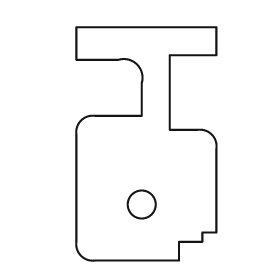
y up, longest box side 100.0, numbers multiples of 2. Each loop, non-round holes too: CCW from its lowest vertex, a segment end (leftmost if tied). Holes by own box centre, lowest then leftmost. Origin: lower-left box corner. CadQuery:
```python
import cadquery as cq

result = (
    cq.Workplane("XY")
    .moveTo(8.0, 0.0)
    .lineTo(44.0, 0.0)
    .lineTo(44.0, 8.0)
    .lineTo(54.0, 8.0)
    .lineTo(54.0, 12.0)
    .lineTo(60.0, 12.0)
    .lineTo(60.0, 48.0)
    .threePointArc((58.0, 54.0), (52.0, 56.0))
    .lineTo(40.0, 56.0)
    .lineTo(40.0, 88.0)
    .lineTo(60.0, 88.0)
    .lineTo(60.0, 100.0)
    .lineTo(0.0, 100.0)
    .lineTo(0.0, 86.0)
    .lineTo(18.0, 86.0)
    .threePointArc((26.0, 84.0), (28.0, 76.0))
    .lineTo(28.0, 62.0)
    .lineTo(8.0, 62.0)
    .threePointArc((2.0, 60.0), (0.0, 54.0))
    .lineTo(0.0, 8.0)
    .threePointArc((2.0, 2.0), (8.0, 0.0))
    .close()
    .moveTo(28.0, 24.0)
    .circle(6.0)
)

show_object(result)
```